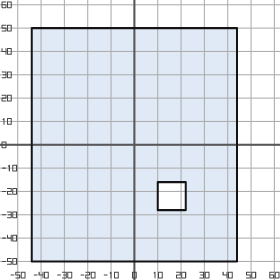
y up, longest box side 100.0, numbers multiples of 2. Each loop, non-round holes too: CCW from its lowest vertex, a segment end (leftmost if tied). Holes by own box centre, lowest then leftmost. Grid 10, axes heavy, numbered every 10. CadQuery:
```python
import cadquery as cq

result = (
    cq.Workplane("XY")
    .moveTo(-44.0, -50.0)
    .lineTo(44.0, -50.0)
    .lineTo(44.0, 50.0)
    .lineTo(-44.0, 50.0)
    .close()
    .moveTo(10.0, -28.0)
    .lineTo(22.0, -28.0)
    .lineTo(22.0, -16.0)
    .lineTo(10.0, -16.0)
    .close()
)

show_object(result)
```